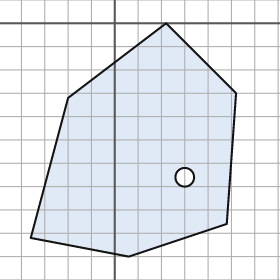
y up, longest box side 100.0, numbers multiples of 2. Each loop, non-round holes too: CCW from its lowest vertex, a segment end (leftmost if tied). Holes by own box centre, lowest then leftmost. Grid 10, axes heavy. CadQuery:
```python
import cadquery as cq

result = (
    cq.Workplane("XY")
    .moveTo(6.0, -100.0)
    .lineTo(48.0, -86.0)
    .lineTo(52.0, -30.0)
    .lineTo(22.0, 0.0)
    .lineTo(-20.0, -32.0)
    .lineTo(-36.0, -92.0)
    .close()
    .moveTo(30.0, -66.0)
    .circle(4.0)
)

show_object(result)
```